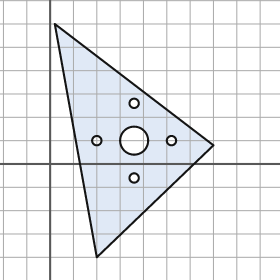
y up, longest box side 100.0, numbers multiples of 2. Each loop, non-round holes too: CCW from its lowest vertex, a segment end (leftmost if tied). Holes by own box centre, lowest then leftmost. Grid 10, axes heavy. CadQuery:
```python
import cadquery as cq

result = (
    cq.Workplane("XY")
    .moveTo(20.0, -40.0)
    .lineTo(70.0, 8.0)
    .lineTo(2.0, 60.0)
    .close()
    .moveTo(36.0, -6.0)
    .circle(2.0)
    .moveTo(20.0, 10.0)
    .circle(2.0)
    .moveTo(36.0, 10.0)
    .circle(6.0)
    .moveTo(52.0, 10.0)
    .circle(2.0)
    .moveTo(36.0, 26.0)
    .circle(2.0)
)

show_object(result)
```